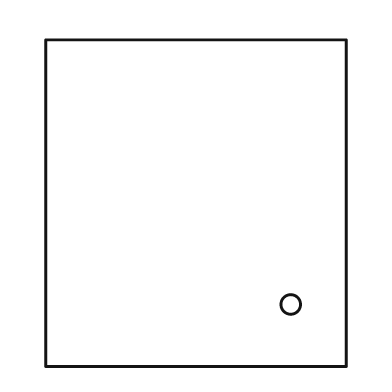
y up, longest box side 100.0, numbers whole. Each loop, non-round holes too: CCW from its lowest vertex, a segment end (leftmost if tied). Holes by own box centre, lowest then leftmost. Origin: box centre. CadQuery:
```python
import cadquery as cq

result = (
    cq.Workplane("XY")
    .moveTo(-46.0, -50.0)
    .lineTo(46.0, -50.0)
    .lineTo(46.0, 50.0)
    .lineTo(-46.0, 50.0)
    .close()
    .moveTo(29.0, -31.0)
    .circle(3.0)
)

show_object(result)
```